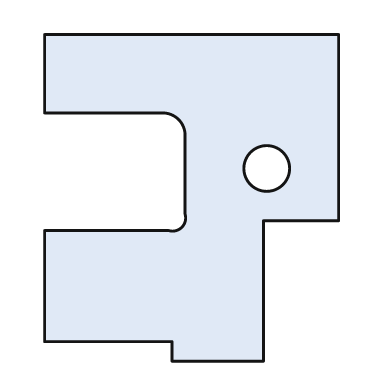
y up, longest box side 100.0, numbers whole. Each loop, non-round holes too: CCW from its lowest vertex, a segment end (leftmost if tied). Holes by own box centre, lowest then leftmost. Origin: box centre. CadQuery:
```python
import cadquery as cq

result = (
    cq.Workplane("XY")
    .moveTo(-6.0, -50.0)
    .lineTo(22.0, -50.0)
    .lineTo(22.0, -7.0)
    .lineTo(45.0, -7.0)
    .lineTo(45.0, 50.0)
    .lineTo(-45.0, 50.0)
    .lineTo(-45.0, 26.0)
    .lineTo(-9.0, 26.0)
    .threePointArc((-4.0, 24.0), (-2.0, 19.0))
    .lineTo(-2.0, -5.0)
    .threePointArc((-3.0, -9.0), (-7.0, -10.0))
    .lineTo(-45.0, -10.0)
    .lineTo(-45.0, -44.0)
    .lineTo(-6.0, -44.0)
    .close()
    .moveTo(23.0, 9.0)
    .circle(7.0)
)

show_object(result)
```